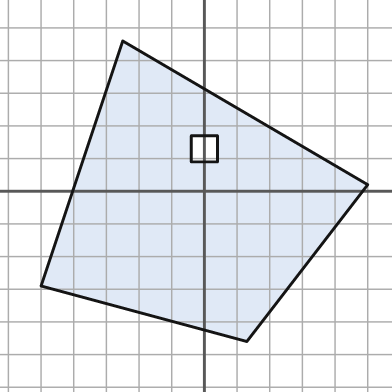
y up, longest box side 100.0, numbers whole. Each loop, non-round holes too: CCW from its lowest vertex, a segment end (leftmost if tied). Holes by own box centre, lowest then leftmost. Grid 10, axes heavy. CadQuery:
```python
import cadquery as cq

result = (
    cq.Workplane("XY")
    .moveTo(13.0, -46.0)
    .lineTo(50.0, 2.0)
    .lineTo(-25.0, 46.0)
    .lineTo(-50.0, -29.0)
    .close()
    .moveTo(-4.0, 9.0)
    .lineTo(4.0, 9.0)
    .lineTo(4.0, 17.0)
    .lineTo(-4.0, 17.0)
    .close()
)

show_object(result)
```